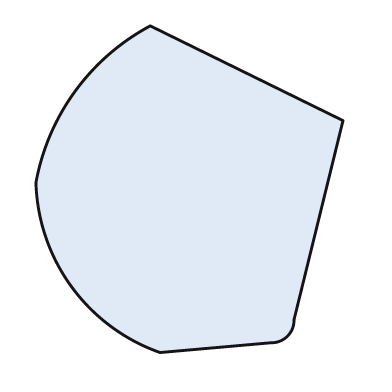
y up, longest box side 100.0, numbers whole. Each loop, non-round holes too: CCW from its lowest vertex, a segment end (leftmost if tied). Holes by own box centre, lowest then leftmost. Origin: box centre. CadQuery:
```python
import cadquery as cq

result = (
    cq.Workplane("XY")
    .moveTo(-9.0, -50.0)
    .lineTo(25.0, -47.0)
    .threePointArc((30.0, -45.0), (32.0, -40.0))
    .lineTo(47.0, 21.0)
    .lineTo(-12.0, 50.0)
    .threePointArc((-35.0, 30.0), (-47.0, 2.0))
    .threePointArc((-36.0, -30.0), (-9.0, -50.0))
    .close()
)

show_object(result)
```